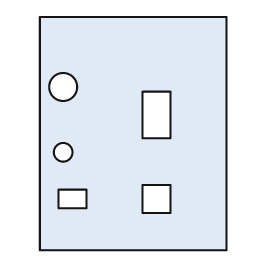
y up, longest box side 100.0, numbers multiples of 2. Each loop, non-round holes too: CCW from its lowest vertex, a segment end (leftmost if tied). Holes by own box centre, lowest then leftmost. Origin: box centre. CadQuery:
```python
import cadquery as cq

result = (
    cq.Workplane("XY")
    .moveTo(-40.0, -50.0)
    .lineTo(40.0, -50.0)
    .lineTo(40.0, 50.0)
    .lineTo(-40.0, 50.0)
    .close()
    .moveTo(-32.0, -32.0)
    .lineTo(-20.0, -32.0)
    .lineTo(-20.0, -24.0)
    .lineTo(-32.0, -24.0)
    .close()
    .moveTo(4.0, -34.0)
    .lineTo(16.0, -34.0)
    .lineTo(16.0, -22.0)
    .lineTo(4.0, -22.0)
    .close()
    .moveTo(-30.0, -8.0)
    .circle(4.0)
    .moveTo(4.0, -2.0)
    .lineTo(16.0, -2.0)
    .lineTo(16.0, 18.0)
    .lineTo(4.0, 18.0)
    .close()
    .moveTo(-30.0, 20.0)
    .circle(6.0)
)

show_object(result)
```